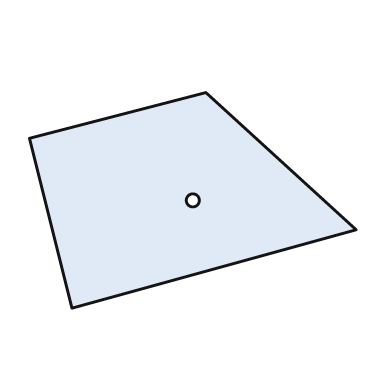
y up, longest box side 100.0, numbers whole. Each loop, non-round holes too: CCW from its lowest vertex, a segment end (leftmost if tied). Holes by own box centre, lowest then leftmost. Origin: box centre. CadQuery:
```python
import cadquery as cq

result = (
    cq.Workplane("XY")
    .moveTo(-37.0, -33.0)
    .lineTo(50.0, -9.0)
    .lineTo(4.0, 33.0)
    .lineTo(-50.0, 19.0)
    .close()
    .moveTo(0.0, 0.0)
    .circle(2.0)
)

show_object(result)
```